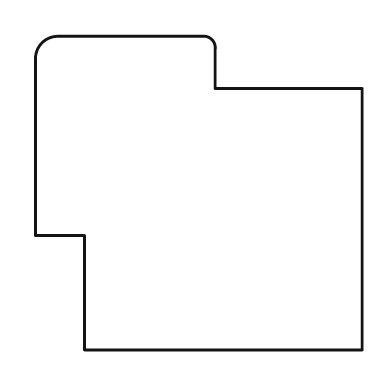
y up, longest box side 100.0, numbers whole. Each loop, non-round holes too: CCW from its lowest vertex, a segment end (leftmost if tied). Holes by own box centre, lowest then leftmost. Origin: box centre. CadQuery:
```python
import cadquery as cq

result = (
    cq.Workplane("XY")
    .moveTo(-35.0, -48.0)
    .lineTo(50.0, -48.0)
    .lineTo(50.0, 32.0)
    .lineTo(5.0, 32.0)
    .lineTo(5.0, 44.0)
    .threePointArc((4.0, 47.0), (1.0, 48.0))
    .lineTo(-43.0, 48.0)
    .threePointArc((-48.0, 46.0), (-50.0, 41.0))
    .lineTo(-50.0, -13.0)
    .lineTo(-35.0, -13.0)
    .close()
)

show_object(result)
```